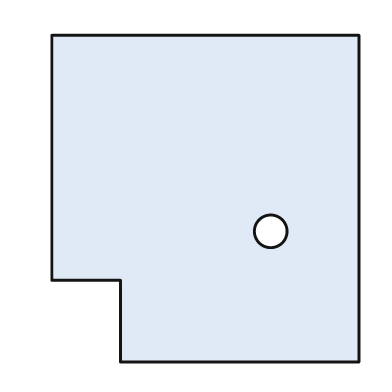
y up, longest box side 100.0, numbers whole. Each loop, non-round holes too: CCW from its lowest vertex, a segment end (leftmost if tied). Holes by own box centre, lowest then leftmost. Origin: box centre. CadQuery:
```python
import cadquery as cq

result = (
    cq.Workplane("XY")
    .moveTo(-26.0, -50.0)
    .lineTo(47.0, -50.0)
    .lineTo(47.0, 50.0)
    .lineTo(-47.0, 50.0)
    .lineTo(-47.0, -25.0)
    .lineTo(-26.0, -25.0)
    .close()
    .moveTo(20.0, -10.0)
    .circle(5.0)
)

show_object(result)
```